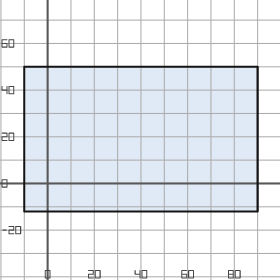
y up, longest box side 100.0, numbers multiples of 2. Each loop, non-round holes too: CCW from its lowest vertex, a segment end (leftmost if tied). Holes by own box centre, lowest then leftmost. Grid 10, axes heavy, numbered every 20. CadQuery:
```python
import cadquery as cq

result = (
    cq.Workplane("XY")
    .moveTo(-10.0, -12.0)
    .lineTo(90.0, -12.0)
    .lineTo(90.0, 50.0)
    .lineTo(-10.0, 50.0)
    .close()
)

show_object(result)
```